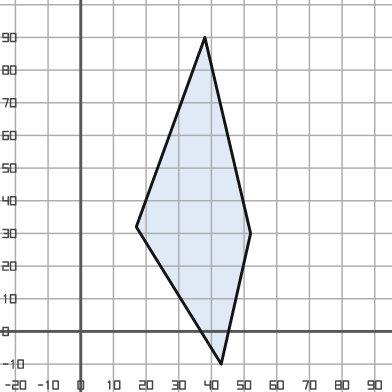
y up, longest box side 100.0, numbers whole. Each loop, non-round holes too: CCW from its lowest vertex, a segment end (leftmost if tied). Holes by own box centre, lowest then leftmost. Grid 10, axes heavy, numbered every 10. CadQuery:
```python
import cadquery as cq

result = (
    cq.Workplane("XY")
    .moveTo(43.0, -10.0)
    .lineTo(52.0, 30.0)
    .lineTo(38.0, 90.0)
    .lineTo(17.0, 32.0)
    .close()
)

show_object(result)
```